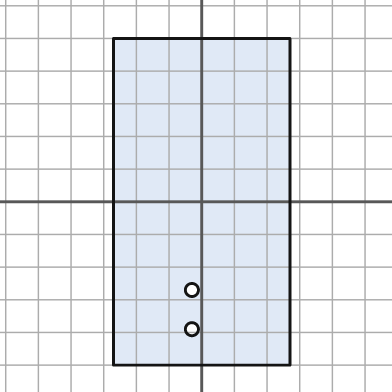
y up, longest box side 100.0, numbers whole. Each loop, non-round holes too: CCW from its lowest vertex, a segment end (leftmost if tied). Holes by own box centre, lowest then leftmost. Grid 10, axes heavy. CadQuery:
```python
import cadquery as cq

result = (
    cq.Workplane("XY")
    .moveTo(-27.0, -50.0)
    .lineTo(27.0, -50.0)
    .lineTo(27.0, 50.0)
    .lineTo(-27.0, 50.0)
    .close()
    .moveTo(-3.0, -39.0)
    .circle(2.0)
    .moveTo(-3.0, -27.0)
    .circle(2.0)
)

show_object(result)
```